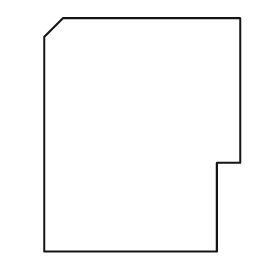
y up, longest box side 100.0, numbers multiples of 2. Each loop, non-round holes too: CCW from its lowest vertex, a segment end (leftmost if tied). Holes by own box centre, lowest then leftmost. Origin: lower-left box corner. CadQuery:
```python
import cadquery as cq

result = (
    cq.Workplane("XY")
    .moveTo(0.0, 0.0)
    .lineTo(74.0, 0.0)
    .lineTo(74.0, 38.0)
    .lineTo(84.0, 38.0)
    .lineTo(84.0, 100.0)
    .lineTo(8.0, 100.0)
    .lineTo(0.0, 92.0)
    .close()
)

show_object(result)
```